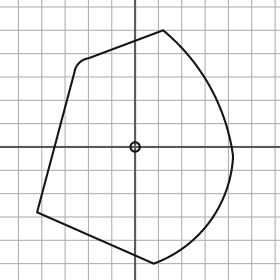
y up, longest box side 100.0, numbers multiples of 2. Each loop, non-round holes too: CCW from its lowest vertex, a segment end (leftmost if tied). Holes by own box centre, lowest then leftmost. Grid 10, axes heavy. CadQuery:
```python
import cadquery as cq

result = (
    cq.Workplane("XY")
    .moveTo(8.0, -50.0)
    .threePointArc((32.0, -32.0), (42.0, -4.0))
    .threePointArc((32.0, 26.0), (12.0, 50.0))
    .lineTo(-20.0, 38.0)
    .threePointArc((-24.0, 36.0), (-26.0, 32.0))
    .lineTo(-42.0, -28.0)
    .close()
    .moveTo(0.0, 0.0)
    .circle(2.0)
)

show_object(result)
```